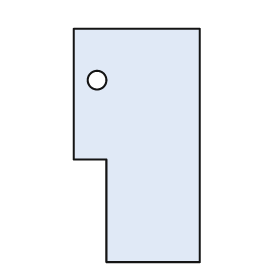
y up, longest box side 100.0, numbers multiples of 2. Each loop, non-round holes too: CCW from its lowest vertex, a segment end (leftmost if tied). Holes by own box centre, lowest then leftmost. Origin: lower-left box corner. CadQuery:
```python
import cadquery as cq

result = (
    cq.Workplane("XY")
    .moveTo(14.0, 0.0)
    .lineTo(54.0, 0.0)
    .lineTo(54.0, 100.0)
    .lineTo(0.0, 100.0)
    .lineTo(0.0, 44.0)
    .lineTo(14.0, 44.0)
    .close()
    .moveTo(10.0, 78.0)
    .circle(4.0)
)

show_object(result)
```